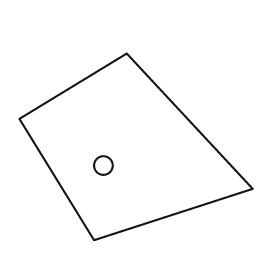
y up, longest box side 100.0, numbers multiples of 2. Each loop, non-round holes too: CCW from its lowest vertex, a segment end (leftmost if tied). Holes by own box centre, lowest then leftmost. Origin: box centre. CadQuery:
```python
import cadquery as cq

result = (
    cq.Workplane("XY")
    .moveTo(-18.0, -40.0)
    .lineTo(50.0, -18.0)
    .lineTo(-4.0, 40.0)
    .lineTo(-50.0, 12.0)
    .close()
    .moveTo(-14.0, -8.0)
    .circle(4.0)
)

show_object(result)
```